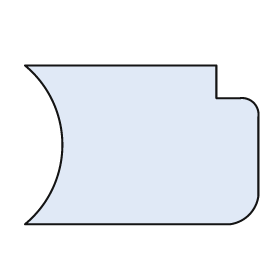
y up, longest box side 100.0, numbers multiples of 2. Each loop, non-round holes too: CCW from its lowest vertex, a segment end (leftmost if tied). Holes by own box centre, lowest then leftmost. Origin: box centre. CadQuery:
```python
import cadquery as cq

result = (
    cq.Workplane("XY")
    .moveTo(-50.0, -34.0)
    .lineTo(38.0, -34.0)
    .threePointArc((46.0, -30.0), (50.0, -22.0))
    .lineTo(50.0, 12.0)
    .threePointArc((48.0, 18.0), (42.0, 20.0))
    .lineTo(32.0, 20.0)
    .lineTo(32.0, 34.0)
    .lineTo(-50.0, 34.0)
    .threePointArc((-34.0, 0.0), (-50.0, -34.0))
    .close()
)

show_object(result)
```